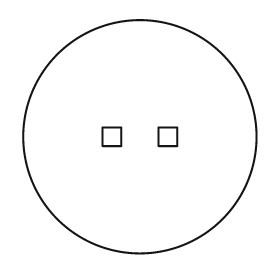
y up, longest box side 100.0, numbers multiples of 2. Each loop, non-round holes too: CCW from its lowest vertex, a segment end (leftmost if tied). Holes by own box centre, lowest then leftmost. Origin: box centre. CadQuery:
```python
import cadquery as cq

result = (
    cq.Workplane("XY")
    .moveTo(0.0, 0.0)
    .circle(50.0)
    .moveTo(-16.0, -4.0)
    .lineTo(-8.0, -4.0)
    .lineTo(-8.0, 4.0)
    .lineTo(-16.0, 4.0)
    .close()
    .moveTo(8.0, -4.0)
    .lineTo(16.0, -4.0)
    .lineTo(16.0, 4.0)
    .lineTo(8.0, 4.0)
    .close()
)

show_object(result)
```